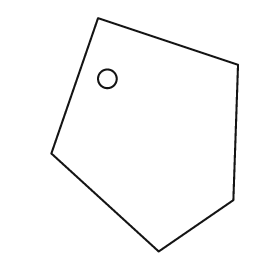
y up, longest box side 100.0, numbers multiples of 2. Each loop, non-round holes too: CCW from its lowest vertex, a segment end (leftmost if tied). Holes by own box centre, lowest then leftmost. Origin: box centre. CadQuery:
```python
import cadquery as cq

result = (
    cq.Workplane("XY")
    .moveTo(6.0, -50.0)
    .lineTo(38.0, -28.0)
    .lineTo(40.0, 30.0)
    .lineTo(-20.0, 50.0)
    .lineTo(-40.0, -8.0)
    .close()
    .moveTo(-16.0, 24.0)
    .circle(4.0)
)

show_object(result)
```